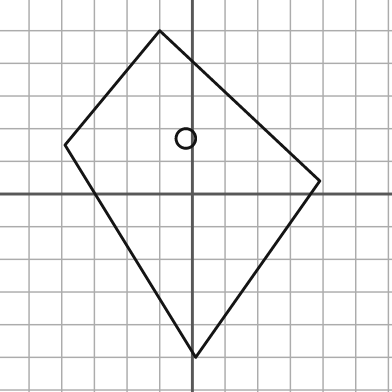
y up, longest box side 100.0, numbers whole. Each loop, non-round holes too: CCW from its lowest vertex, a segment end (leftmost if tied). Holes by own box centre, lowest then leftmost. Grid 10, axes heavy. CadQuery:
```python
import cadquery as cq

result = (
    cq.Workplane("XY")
    .moveTo(1.0, -50.0)
    .lineTo(39.0, 4.0)
    .lineTo(-10.0, 50.0)
    .lineTo(-39.0, 15.0)
    .close()
    .moveTo(-2.0, 17.0)
    .circle(3.0)
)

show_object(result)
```